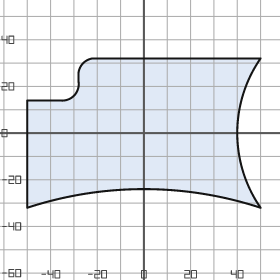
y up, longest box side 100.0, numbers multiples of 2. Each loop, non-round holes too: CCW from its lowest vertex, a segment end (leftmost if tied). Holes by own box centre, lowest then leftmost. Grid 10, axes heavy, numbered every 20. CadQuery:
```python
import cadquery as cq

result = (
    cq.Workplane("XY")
    .moveTo(-50.0, -32.0)
    .threePointArc((0.0, -24.0), (50.0, -32.0))
    .threePointArc((40.0, 0.0), (50.0, 32.0))
    .lineTo(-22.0, 32.0)
    .threePointArc((-26.0, 30.0), (-28.0, 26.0))
    .lineTo(-28.0, 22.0)
    .threePointArc((-30.0, 16.0), (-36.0, 14.0))
    .lineTo(-50.0, 14.0)
    .close()
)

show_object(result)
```